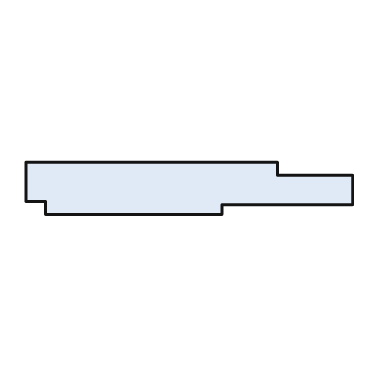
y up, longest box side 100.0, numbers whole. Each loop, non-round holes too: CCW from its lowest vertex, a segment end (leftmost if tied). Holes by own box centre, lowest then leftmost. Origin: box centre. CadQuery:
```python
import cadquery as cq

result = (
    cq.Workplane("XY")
    .moveTo(-44.0, -8.0)
    .lineTo(10.0, -8.0)
    .lineTo(10.0, -5.0)
    .lineTo(50.0, -5.0)
    .lineTo(50.0, 4.0)
    .lineTo(27.0, 4.0)
    .lineTo(27.0, 8.0)
    .lineTo(-50.0, 8.0)
    .lineTo(-50.0, -4.0)
    .lineTo(-44.0, -4.0)
    .close()
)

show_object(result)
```